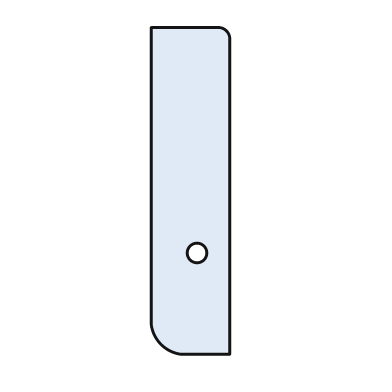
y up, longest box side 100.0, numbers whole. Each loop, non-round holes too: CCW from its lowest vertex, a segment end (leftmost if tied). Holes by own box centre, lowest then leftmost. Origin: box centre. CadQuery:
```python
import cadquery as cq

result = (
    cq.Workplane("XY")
    .moveTo(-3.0, -50.0)
    .lineTo(12.0, -50.0)
    .lineTo(12.0, 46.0)
    .threePointArc((11.0, 49.0), (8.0, 50.0))
    .lineTo(-12.0, 50.0)
    .lineTo(-12.0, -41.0)
    .threePointArc((-9.0, -47.0), (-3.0, -50.0))
    .close()
    .moveTo(2.0, -19.0)
    .circle(3.0)
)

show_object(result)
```